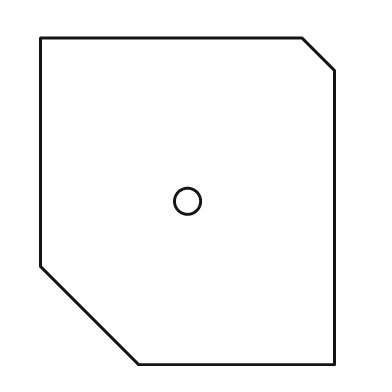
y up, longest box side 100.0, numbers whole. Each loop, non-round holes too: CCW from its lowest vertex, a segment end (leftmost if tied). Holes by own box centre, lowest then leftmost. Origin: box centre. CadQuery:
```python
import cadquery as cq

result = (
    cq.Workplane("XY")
    .moveTo(-15.0, -50.0)
    .lineTo(45.0, -50.0)
    .lineTo(45.0, 40.0)
    .lineTo(35.0, 50.0)
    .lineTo(-45.0, 50.0)
    .lineTo(-45.0, -20.0)
    .close()
    .moveTo(0.0, 0.0)
    .circle(4.0)
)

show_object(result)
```